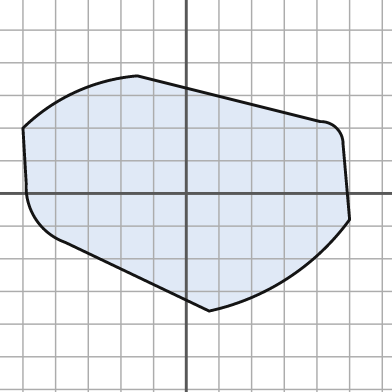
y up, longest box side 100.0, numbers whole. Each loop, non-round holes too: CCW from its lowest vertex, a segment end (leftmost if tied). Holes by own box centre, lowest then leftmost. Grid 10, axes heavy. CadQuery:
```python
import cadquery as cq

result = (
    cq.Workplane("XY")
    .moveTo(7.0, -36.0)
    .threePointArc((31.0, -26.0), (50.0, -8.0))
    .lineTo(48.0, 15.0)
    .threePointArc((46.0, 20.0), (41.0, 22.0))
    .lineTo(-15.0, 36.0)
    .threePointArc((-34.0, 31.0), (-50.0, 20.0))
    .lineTo(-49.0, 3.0)
    .threePointArc((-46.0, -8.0), (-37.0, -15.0))
    .close()
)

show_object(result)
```